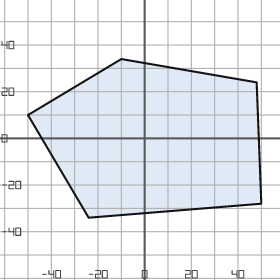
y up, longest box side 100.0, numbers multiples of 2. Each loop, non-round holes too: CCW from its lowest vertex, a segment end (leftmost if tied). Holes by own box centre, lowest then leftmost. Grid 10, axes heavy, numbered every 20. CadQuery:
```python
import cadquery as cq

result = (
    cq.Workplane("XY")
    .moveTo(-24.0, -34.0)
    .lineTo(50.0, -28.0)
    .lineTo(48.0, 24.0)
    .lineTo(-10.0, 34.0)
    .lineTo(-50.0, 10.0)
    .close()
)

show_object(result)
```